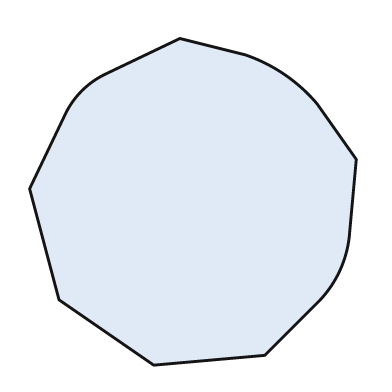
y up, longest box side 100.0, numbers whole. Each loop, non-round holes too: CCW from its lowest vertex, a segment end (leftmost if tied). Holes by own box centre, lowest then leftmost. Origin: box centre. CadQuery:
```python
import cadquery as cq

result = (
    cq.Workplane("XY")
    .moveTo(-12.0, -50.0)
    .lineTo(22.0, -47.0)
    .lineTo(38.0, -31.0)
    .threePointArc((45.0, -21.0), (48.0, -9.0))
    .lineTo(50.0, 13.0)
    .lineTo(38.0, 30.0)
    .threePointArc((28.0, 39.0), (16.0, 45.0))
    .lineTo(-4.0, 50.0)
    .lineTo(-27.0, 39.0)
    .threePointArc((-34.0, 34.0), (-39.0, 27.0))
    .lineTo(-50.0, 4.0)
    .lineTo(-41.0, -30.0)
    .close()
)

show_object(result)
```